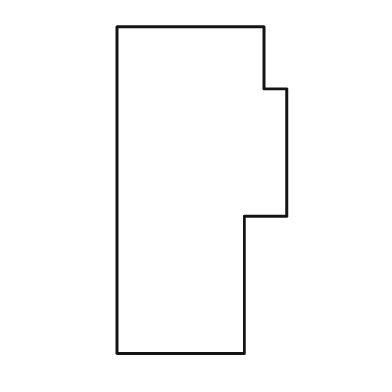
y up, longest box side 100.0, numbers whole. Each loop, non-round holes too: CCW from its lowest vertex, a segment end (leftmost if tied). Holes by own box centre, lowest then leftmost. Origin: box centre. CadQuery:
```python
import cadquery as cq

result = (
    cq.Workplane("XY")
    .moveTo(-26.0, -50.0)
    .lineTo(13.0, -50.0)
    .lineTo(13.0, -8.0)
    .lineTo(26.0, -8.0)
    .lineTo(26.0, 31.0)
    .lineTo(19.0, 31.0)
    .lineTo(19.0, 50.0)
    .lineTo(-26.0, 50.0)
    .close()
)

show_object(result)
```